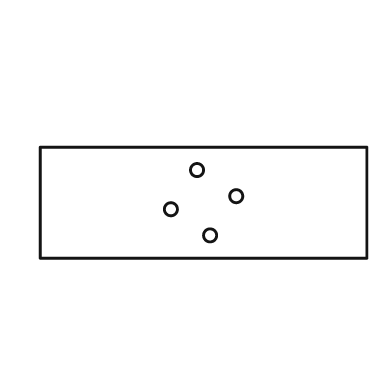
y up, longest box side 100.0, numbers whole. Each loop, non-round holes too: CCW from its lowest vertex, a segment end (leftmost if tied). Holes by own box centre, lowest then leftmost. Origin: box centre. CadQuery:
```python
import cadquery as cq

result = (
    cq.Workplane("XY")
    .moveTo(-50.0, -17.0)
    .lineTo(50.0, -17.0)
    .lineTo(50.0, 17.0)
    .lineTo(-50.0, 17.0)
    .close()
    .moveTo(2.0, -10.0)
    .circle(2.0)
    .moveTo(-10.0, -2.0)
    .circle(2.0)
    .moveTo(10.0, 2.0)
    .circle(2.0)
    .moveTo(-2.0, 10.0)
    .circle(2.0)
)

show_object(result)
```